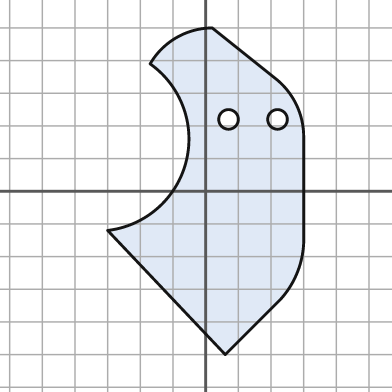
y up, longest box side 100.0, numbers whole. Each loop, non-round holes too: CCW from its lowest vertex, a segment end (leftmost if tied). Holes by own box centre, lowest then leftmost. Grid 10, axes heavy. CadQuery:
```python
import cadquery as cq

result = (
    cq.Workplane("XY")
    .moveTo(6.0, -50.0)
    .lineTo(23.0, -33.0)
    .threePointArc((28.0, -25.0), (30.0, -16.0))
    .lineTo(30.0, 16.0)
    .threePointArc((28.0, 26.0), (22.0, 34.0))
    .lineTo(2.0, 50.0)
    .threePointArc((-9.0, 47.0), (-17.0, 39.0))
    .threePointArc((-6.0, 9.0), (-30.0, -12.0))
    .close()
    .moveTo(7.0, 22.0)
    .circle(3.0)
    .moveTo(22.0, 22.0)
    .circle(3.0)
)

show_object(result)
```